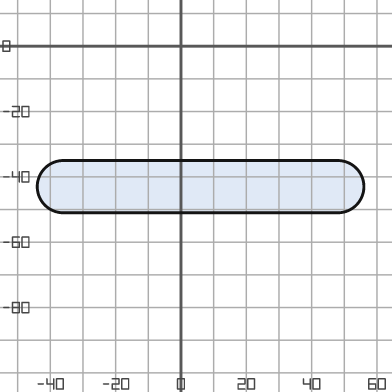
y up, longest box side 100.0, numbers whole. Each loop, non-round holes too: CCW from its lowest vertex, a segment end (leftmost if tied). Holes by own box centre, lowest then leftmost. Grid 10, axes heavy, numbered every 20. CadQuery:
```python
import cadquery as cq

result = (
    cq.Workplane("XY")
    .moveTo(-36.0, -51.0)
    .lineTo(48.0, -51.0)
    .threePointArc((56.0, -43.0), (48.0, -35.0))
    .lineTo(-36.0, -35.0)
    .threePointArc((-44.0, -43.0), (-36.0, -51.0))
    .close()
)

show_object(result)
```